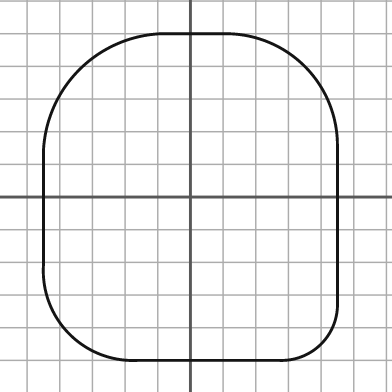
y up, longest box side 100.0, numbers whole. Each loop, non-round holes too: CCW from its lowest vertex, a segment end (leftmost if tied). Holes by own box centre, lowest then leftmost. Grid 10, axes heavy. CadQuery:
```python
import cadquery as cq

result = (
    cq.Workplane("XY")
    .moveTo(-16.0, -50.0)
    .lineTo(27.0, -50.0)
    .threePointArc((40.0, -45.0), (45.0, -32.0))
    .lineTo(45.0, 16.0)
    .threePointArc((35.0, 40.0), (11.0, 50.0))
    .lineTo(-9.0, 50.0)
    .threePointArc((-34.0, 39.0), (-45.0, 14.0))
    .lineTo(-45.0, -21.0)
    .threePointArc((-37.0, -42.0), (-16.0, -50.0))
    .close()
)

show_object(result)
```